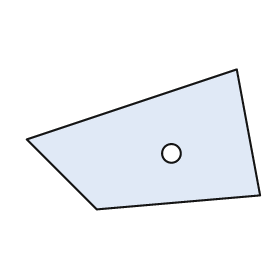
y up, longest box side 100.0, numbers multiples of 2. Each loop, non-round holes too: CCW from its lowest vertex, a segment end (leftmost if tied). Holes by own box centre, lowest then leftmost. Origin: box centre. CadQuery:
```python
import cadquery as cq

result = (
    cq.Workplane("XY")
    .moveTo(-20.0, -30.0)
    .lineTo(50.0, -24.0)
    .lineTo(40.0, 30.0)
    .lineTo(-50.0, 0.0)
    .close()
    .moveTo(12.0, -6.0)
    .circle(4.0)
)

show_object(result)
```